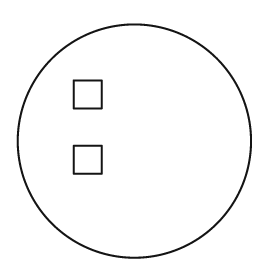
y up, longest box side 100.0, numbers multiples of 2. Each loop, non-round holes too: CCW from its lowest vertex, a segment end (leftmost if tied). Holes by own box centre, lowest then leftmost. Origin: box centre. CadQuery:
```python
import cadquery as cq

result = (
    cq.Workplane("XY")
    .moveTo(0.0, 0.0)
    .circle(50.0)
    .moveTo(-26.0, -14.0)
    .lineTo(-14.0, -14.0)
    .lineTo(-14.0, -2.0)
    .lineTo(-26.0, -2.0)
    .close()
    .moveTo(-26.0, 14.0)
    .lineTo(-14.0, 14.0)
    .lineTo(-14.0, 26.0)
    .lineTo(-26.0, 26.0)
    .close()
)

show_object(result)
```